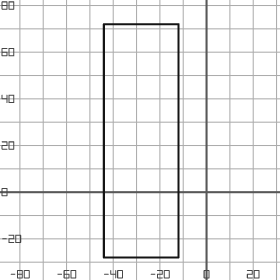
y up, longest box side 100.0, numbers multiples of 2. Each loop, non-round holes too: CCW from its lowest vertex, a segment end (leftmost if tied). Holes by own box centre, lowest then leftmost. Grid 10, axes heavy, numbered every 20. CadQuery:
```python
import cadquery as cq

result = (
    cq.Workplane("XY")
    .moveTo(-44.0, -28.0)
    .lineTo(-12.0, -28.0)
    .lineTo(-12.0, 72.0)
    .lineTo(-44.0, 72.0)
    .close()
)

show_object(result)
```